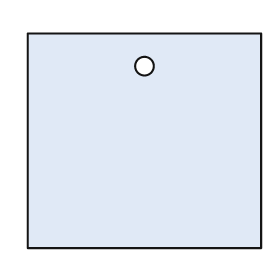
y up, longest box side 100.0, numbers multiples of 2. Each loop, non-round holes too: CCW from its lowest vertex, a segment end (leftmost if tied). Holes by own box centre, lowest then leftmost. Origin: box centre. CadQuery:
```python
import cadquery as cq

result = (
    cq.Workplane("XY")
    .moveTo(-50.0, -46.0)
    .lineTo(50.0, -46.0)
    .lineTo(50.0, 46.0)
    .lineTo(-50.0, 46.0)
    .close()
    .moveTo(0.0, 32.0)
    .circle(4.0)
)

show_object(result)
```